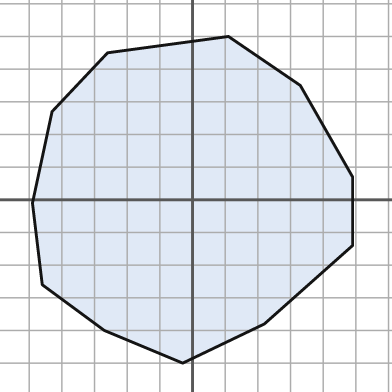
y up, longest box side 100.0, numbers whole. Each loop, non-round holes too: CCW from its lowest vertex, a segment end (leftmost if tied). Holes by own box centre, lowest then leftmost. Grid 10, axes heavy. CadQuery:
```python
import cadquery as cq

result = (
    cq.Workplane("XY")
    .moveTo(-3.0, -50.0)
    .lineTo(22.0, -38.0)
    .lineTo(49.0, -14.0)
    .lineTo(49.0, 7.0)
    .lineTo(33.0, 35.0)
    .lineTo(11.0, 50.0)
    .lineTo(-26.0, 45.0)
    .lineTo(-43.0, 27.0)
    .lineTo(-49.0, -1.0)
    .lineTo(-46.0, -26.0)
    .lineTo(-27.0, -40.0)
    .close()
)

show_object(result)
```